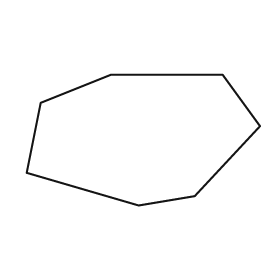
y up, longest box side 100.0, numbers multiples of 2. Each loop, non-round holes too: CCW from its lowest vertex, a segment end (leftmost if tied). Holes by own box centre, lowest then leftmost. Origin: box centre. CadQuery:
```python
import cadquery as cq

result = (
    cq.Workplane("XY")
    .moveTo(-2.0, -28.0)
    .lineTo(22.0, -24.0)
    .lineTo(50.0, 6.0)
    .lineTo(34.0, 28.0)
    .lineTo(-14.0, 28.0)
    .lineTo(-44.0, 16.0)
    .lineTo(-50.0, -14.0)
    .close()
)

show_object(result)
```